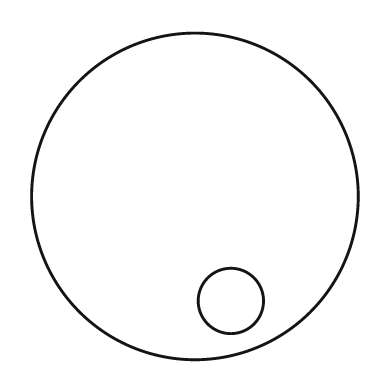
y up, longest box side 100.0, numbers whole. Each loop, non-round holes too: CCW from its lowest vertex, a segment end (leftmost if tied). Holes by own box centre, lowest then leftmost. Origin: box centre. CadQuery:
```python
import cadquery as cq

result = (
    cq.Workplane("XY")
    .moveTo(0.0, 0.0)
    .circle(50.0)
    .moveTo(11.0, -32.0)
    .circle(10.0)
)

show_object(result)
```